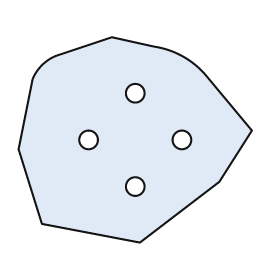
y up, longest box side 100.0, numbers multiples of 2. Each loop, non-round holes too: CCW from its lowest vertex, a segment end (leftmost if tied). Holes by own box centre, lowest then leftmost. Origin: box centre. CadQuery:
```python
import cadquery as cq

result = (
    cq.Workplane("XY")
    .moveTo(2.0, -44.0)
    .lineTo(36.0, -18.0)
    .lineTo(50.0, 4.0)
    .lineTo(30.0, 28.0)
    .threePointArc((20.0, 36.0), (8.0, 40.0))
    .lineTo(-10.0, 44.0)
    .lineTo(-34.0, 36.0)
    .threePointArc((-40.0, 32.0), (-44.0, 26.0))
    .lineTo(-50.0, -4.0)
    .lineTo(-40.0, -36.0)
    .close()
    .moveTo(0.0, -20.0)
    .circle(4.0)
    .moveTo(-20.0, 0.0)
    .circle(4.0)
    .moveTo(20.0, 0.0)
    .circle(4.0)
    .moveTo(0.0, 20.0)
    .circle(4.0)
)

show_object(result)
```